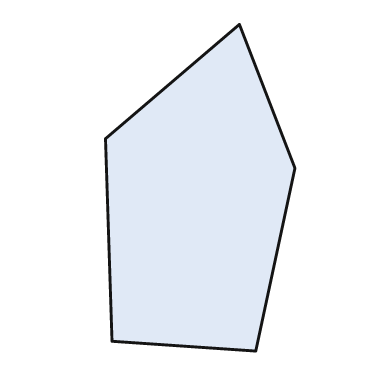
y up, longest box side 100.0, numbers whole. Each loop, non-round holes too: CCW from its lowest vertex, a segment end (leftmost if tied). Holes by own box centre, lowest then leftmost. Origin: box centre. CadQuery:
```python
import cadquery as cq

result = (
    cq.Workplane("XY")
    .moveTo(17.0, -50.0)
    .lineTo(29.0, 6.0)
    .lineTo(12.0, 50.0)
    .lineTo(-29.0, 15.0)
    .lineTo(-27.0, -47.0)
    .close()
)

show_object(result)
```